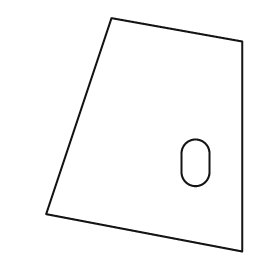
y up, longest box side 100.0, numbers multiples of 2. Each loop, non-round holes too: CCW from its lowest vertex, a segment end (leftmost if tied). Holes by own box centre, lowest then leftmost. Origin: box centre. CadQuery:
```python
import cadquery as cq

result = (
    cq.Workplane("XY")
    .moveTo(42.0, -50.0)
    .lineTo(42.0, 40.0)
    .lineTo(-14.0, 50.0)
    .lineTo(-42.0, -34.0)
    .close()
    .moveTo(16.0, -16.0)
    .threePointArc((22.0, -22.0), (28.0, -16.0))
    .lineTo(28.0, -8.0)
    .threePointArc((22.0, -2.0), (16.0, -8.0))
    .close()
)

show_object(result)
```